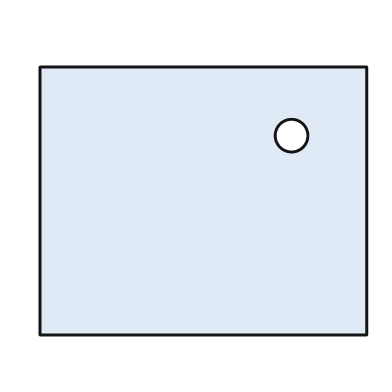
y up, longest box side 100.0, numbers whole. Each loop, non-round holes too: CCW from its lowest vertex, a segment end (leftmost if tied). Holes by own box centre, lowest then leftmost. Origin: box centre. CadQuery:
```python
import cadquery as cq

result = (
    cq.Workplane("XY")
    .moveTo(-50.0, -41.0)
    .lineTo(50.0, -41.0)
    .lineTo(50.0, 41.0)
    .lineTo(-50.0, 41.0)
    .close()
    .moveTo(27.0, 20.0)
    .circle(5.0)
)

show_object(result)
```